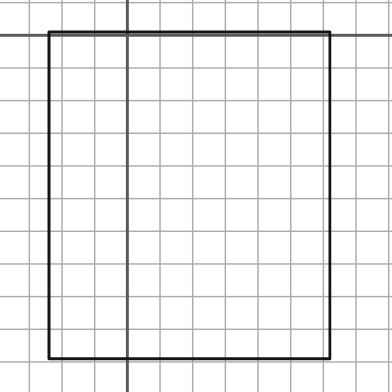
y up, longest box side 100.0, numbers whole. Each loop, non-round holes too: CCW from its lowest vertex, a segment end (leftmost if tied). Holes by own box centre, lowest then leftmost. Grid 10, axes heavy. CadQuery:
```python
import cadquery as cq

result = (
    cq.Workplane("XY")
    .moveTo(-24.0, -99.0)
    .lineTo(62.0, -99.0)
    .lineTo(62.0, 1.0)
    .lineTo(-24.0, 1.0)
    .close()
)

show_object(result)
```